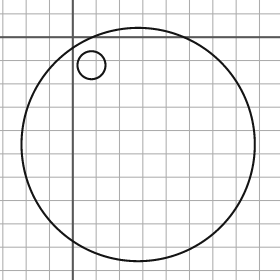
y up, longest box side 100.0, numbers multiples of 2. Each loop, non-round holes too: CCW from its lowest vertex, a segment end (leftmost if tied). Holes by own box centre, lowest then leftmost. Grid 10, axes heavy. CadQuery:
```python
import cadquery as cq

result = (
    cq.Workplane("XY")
    .moveTo(28.0, -46.0)
    .circle(50.0)
    .moveTo(8.0, -12.0)
    .circle(6.0)
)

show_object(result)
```